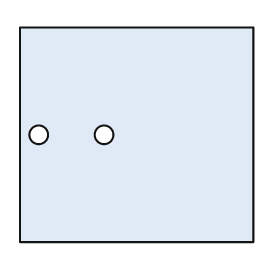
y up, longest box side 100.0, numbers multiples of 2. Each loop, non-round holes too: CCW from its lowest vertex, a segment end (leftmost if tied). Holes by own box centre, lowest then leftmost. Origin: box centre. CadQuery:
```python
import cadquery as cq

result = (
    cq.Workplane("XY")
    .moveTo(-50.0, -46.0)
    .lineTo(50.0, -46.0)
    .lineTo(50.0, 46.0)
    .lineTo(-50.0, 46.0)
    .close()
    .moveTo(-42.0, 0.0)
    .circle(4.0)
    .moveTo(-14.0, 0.0)
    .circle(4.0)
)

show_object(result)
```